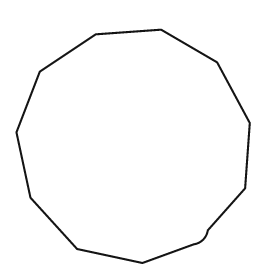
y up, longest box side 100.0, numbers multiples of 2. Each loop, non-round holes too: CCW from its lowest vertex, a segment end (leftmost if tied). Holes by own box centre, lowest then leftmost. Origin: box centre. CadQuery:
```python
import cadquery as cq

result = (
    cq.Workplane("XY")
    .moveTo(4.0, -50.0)
    .lineTo(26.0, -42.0)
    .threePointArc((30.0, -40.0), (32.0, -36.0))
    .lineTo(48.0, -18.0)
    .lineTo(50.0, 10.0)
    .lineTo(36.0, 36.0)
    .lineTo(12.0, 50.0)
    .lineTo(-16.0, 48.0)
    .lineTo(-40.0, 32.0)
    .lineTo(-50.0, 6.0)
    .lineTo(-44.0, -22.0)
    .lineTo(-24.0, -44.0)
    .close()
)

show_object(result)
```